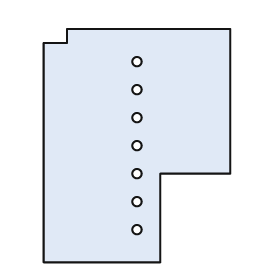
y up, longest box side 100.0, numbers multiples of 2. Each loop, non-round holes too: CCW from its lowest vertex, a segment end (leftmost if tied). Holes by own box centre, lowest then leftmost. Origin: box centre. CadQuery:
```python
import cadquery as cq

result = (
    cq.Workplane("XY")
    .moveTo(-40.0, -50.0)
    .lineTo(10.0, -50.0)
    .lineTo(10.0, -12.0)
    .lineTo(40.0, -12.0)
    .lineTo(40.0, 50.0)
    .lineTo(-30.0, 50.0)
    .lineTo(-30.0, 44.0)
    .lineTo(-40.0, 44.0)
    .close()
    .moveTo(0.0, -36.0)
    .circle(2.0)
    .moveTo(0.0, -24.0)
    .circle(2.0)
    .moveTo(0.0, -12.0)
    .circle(2.0)
    .moveTo(0.0, 0.0)
    .circle(2.0)
    .moveTo(0.0, 12.0)
    .circle(2.0)
    .moveTo(0.0, 24.0)
    .circle(2.0)
    .moveTo(0.0, 36.0)
    .circle(2.0)
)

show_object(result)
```